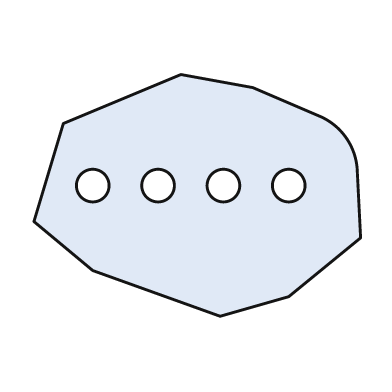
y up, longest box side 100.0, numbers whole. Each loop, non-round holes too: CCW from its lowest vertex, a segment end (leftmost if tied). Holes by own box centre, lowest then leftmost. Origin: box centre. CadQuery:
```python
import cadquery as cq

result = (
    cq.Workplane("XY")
    .moveTo(7.0, -37.0)
    .lineTo(28.0, -31.0)
    .lineTo(50.0, -13.0)
    .lineTo(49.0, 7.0)
    .threePointArc((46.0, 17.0), (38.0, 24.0))
    .lineTo(17.0, 33.0)
    .lineTo(-5.0, 37.0)
    .lineTo(-41.0, 22.0)
    .lineTo(-50.0, -8.0)
    .lineTo(-32.0, -23.0)
    .close()
    .moveTo(-32.0, 3.0)
    .circle(5.0)
    .moveTo(-12.0, 3.0)
    .circle(5.0)
    .moveTo(8.0, 3.0)
    .circle(5.0)
    .moveTo(28.0, 3.0)
    .circle(5.0)
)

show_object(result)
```